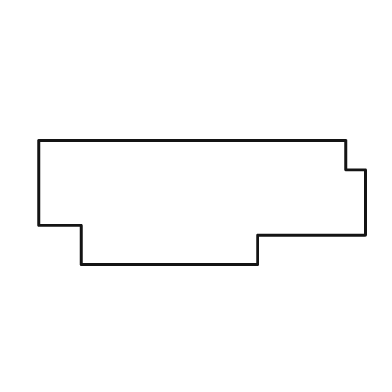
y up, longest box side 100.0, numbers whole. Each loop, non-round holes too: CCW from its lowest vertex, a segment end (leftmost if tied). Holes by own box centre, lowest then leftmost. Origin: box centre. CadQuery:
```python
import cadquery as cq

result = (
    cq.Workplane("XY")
    .moveTo(-37.0, -19.0)
    .lineTo(17.0, -19.0)
    .lineTo(17.0, -10.0)
    .lineTo(50.0, -10.0)
    .lineTo(50.0, 10.0)
    .lineTo(44.0, 10.0)
    .lineTo(44.0, 19.0)
    .lineTo(-50.0, 19.0)
    .lineTo(-50.0, -7.0)
    .lineTo(-37.0, -7.0)
    .close()
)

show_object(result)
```